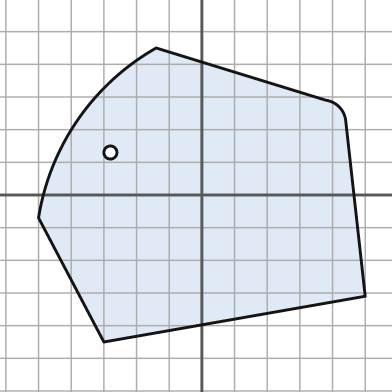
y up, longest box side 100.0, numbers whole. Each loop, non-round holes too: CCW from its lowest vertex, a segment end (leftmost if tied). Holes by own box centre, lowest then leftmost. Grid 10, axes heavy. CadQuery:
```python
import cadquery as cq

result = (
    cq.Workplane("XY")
    .moveTo(-30.0, -45.0)
    .lineTo(50.0, -31.0)
    .lineTo(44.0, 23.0)
    .threePointArc((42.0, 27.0), (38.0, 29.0))
    .lineTo(-14.0, 45.0)
    .threePointArc((-38.0, 23.0), (-50.0, -7.0))
    .close()
    .moveTo(-28.0, 13.0)
    .circle(2.0)
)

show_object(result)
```